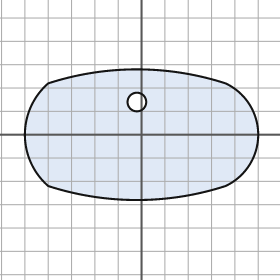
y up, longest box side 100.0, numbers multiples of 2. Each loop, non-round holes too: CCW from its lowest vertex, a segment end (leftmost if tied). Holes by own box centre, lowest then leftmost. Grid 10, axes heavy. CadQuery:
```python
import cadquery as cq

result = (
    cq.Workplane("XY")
    .moveTo(-40.0, -22.0)
    .threePointArc((-2.0, -28.0), (36.0, -22.0))
    .threePointArc((50.0, 0.0), (36.0, 22.0))
    .threePointArc((-2.0, 28.0), (-40.0, 22.0))
    .threePointArc((-50.0, 0.0), (-40.0, -22.0))
    .close()
    .moveTo(-2.0, 14.0)
    .circle(4.0)
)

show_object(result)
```